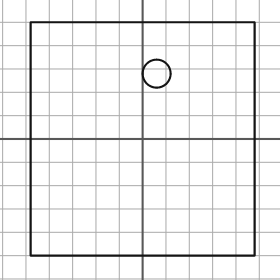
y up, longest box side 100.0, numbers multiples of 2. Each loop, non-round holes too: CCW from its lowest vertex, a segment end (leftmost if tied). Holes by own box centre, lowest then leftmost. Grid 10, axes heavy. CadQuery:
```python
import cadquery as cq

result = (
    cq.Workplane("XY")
    .moveTo(-48.0, -50.0)
    .lineTo(48.0, -50.0)
    .lineTo(48.0, 50.0)
    .lineTo(-48.0, 50.0)
    .close()
    .moveTo(6.0, 28.0)
    .circle(6.0)
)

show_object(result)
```